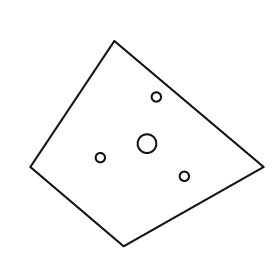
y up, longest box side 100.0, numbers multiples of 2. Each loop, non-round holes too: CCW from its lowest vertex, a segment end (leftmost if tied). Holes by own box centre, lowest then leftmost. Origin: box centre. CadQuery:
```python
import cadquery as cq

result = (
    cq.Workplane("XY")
    .moveTo(-10.0, -44.0)
    .lineTo(50.0, -10.0)
    .lineTo(-14.0, 44.0)
    .lineTo(-50.0, -10.0)
    .close()
    .moveTo(16.0, -14.0)
    .circle(2.0)
    .moveTo(-20.0, -6.0)
    .circle(2.0)
    .moveTo(0.0, 0.0)
    .circle(4.0)
    .moveTo(4.0, 20.0)
    .circle(2.0)
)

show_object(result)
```